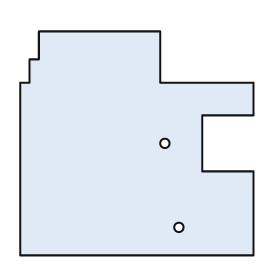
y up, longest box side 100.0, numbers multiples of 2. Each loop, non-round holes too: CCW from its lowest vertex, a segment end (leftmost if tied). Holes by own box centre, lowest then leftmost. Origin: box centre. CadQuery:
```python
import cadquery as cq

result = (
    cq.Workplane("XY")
    .moveTo(-50.0, -48.0)
    .lineTo(50.0, -48.0)
    .lineTo(50.0, -12.0)
    .lineTo(28.0, -12.0)
    .lineTo(28.0, 12.0)
    .lineTo(50.0, 12.0)
    .lineTo(50.0, 26.0)
    .lineTo(10.0, 26.0)
    .lineTo(10.0, 48.0)
    .lineTo(-42.0, 48.0)
    .lineTo(-42.0, 36.0)
    .lineTo(-46.0, 36.0)
    .lineTo(-46.0, 26.0)
    .lineTo(-50.0, 26.0)
    .close()
    .moveTo(18.0, -36.0)
    .circle(2.0)
    .moveTo(12.0, 0.0)
    .circle(2.0)
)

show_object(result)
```